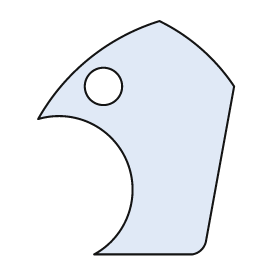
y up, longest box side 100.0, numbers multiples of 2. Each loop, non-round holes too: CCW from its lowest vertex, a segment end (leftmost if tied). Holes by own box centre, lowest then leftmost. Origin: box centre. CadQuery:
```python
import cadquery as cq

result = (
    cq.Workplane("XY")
    .moveTo(-18.0, -50.0)
    .lineTo(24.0, -50.0)
    .threePointArc((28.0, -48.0), (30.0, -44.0))
    .lineTo(42.0, 22.0)
    .threePointArc((28.0, 38.0), (10.0, 50.0))
    .threePointArc((-20.0, 34.0), (-42.0, 8.0))
    .threePointArc((-4.0, -10.0), (-18.0, -50.0))
    .close()
    .moveTo(-14.0, 22.0)
    .circle(8.0)
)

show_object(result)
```